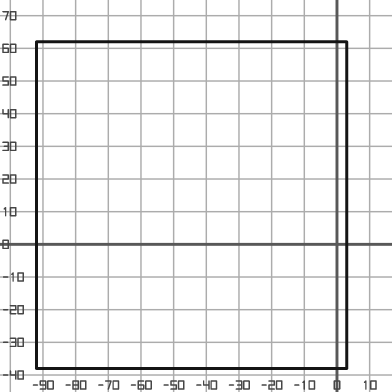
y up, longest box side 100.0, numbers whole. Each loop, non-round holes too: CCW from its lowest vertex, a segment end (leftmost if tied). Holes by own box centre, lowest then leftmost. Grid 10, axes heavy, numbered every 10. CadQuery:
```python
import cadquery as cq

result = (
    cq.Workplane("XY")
    .moveTo(-92.0, -38.0)
    .lineTo(3.0, -38.0)
    .lineTo(3.0, 62.0)
    .lineTo(-92.0, 62.0)
    .close()
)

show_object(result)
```